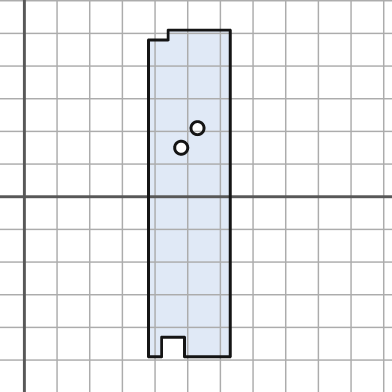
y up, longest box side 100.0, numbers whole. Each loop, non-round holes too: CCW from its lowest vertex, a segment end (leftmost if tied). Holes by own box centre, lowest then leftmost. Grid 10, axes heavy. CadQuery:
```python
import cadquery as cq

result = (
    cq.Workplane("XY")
    .moveTo(38.0, -49.0)
    .lineTo(42.0, -49.0)
    .lineTo(42.0, -43.0)
    .lineTo(49.0, -43.0)
    .lineTo(49.0, -49.0)
    .lineTo(63.0, -49.0)
    .lineTo(63.0, 51.0)
    .lineTo(44.0, 51.0)
    .lineTo(44.0, 48.0)
    .lineTo(38.0, 48.0)
    .close()
    .moveTo(48.0, 15.0)
    .circle(2.0)
    .moveTo(53.0, 21.0)
    .circle(2.0)
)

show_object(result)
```